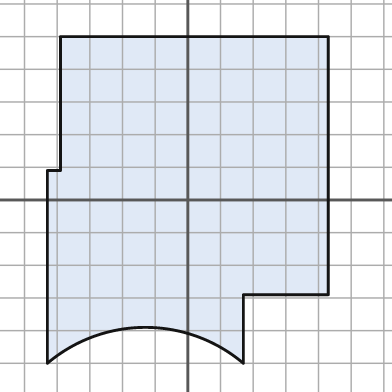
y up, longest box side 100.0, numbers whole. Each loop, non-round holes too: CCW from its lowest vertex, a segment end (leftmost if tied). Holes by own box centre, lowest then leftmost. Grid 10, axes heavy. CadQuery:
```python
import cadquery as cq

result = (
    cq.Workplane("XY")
    .moveTo(-43.0, -50.0)
    .threePointArc((-13.0, -39.0), (17.0, -50.0))
    .lineTo(17.0, -29.0)
    .lineTo(43.0, -29.0)
    .lineTo(43.0, 50.0)
    .lineTo(-39.0, 50.0)
    .lineTo(-39.0, 9.0)
    .lineTo(-43.0, 9.0)
    .close()
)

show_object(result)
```